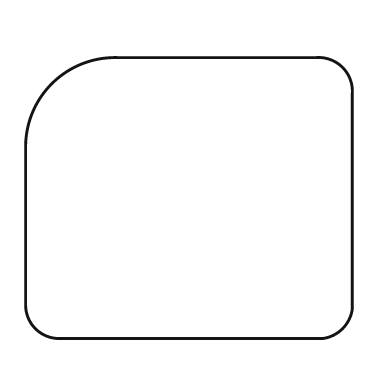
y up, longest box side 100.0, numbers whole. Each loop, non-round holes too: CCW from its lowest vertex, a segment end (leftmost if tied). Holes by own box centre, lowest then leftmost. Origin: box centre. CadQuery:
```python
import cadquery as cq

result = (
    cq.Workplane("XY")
    .moveTo(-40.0, -43.0)
    .lineTo(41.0, -43.0)
    .threePointArc((47.0, -40.0), (50.0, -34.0))
    .lineTo(50.0, 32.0)
    .threePointArc((47.0, 40.0), (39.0, 43.0))
    .lineTo(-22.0, 43.0)
    .threePointArc((-42.0, 35.0), (-50.0, 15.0))
    .lineTo(-50.0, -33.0)
    .threePointArc((-47.0, -40.0), (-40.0, -43.0))
    .close()
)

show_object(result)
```